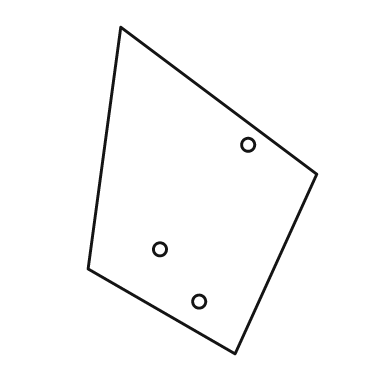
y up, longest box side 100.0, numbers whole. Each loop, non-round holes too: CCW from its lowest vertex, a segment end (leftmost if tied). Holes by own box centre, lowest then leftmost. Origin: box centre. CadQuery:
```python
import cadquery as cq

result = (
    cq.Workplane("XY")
    .moveTo(10.0, -50.0)
    .lineTo(35.0, 5.0)
    .lineTo(-25.0, 50.0)
    .lineTo(-35.0, -24.0)
    .close()
    .moveTo(-1.0, -34.0)
    .circle(2.0)
    .moveTo(-13.0, -18.0)
    .circle(2.0)
    .moveTo(14.0, 14.0)
    .circle(2.0)
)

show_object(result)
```